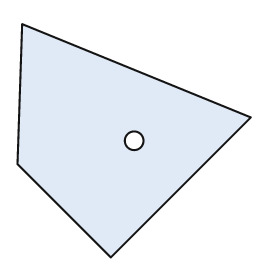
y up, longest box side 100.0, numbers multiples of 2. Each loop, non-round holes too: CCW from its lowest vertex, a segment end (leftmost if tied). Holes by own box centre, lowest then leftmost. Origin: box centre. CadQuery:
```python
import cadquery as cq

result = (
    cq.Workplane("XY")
    .moveTo(-10.0, -50.0)
    .lineTo(50.0, 10.0)
    .lineTo(-48.0, 50.0)
    .lineTo(-50.0, -10.0)
    .close()
    .moveTo(0.0, 0.0)
    .circle(4.0)
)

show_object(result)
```